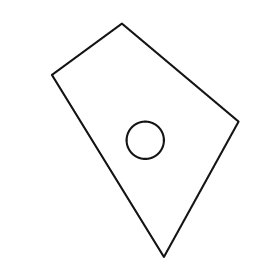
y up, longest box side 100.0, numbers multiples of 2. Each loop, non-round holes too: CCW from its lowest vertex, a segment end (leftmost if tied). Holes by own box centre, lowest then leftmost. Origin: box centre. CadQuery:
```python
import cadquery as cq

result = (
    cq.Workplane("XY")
    .moveTo(8.0, -50.0)
    .lineTo(40.0, 8.0)
    .lineTo(-10.0, 50.0)
    .lineTo(-40.0, 28.0)
    .close()
    .moveTo(0.0, 0.0)
    .circle(8.0)
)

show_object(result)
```